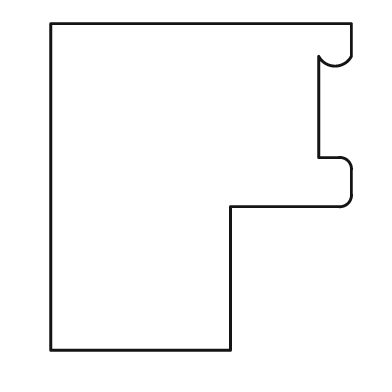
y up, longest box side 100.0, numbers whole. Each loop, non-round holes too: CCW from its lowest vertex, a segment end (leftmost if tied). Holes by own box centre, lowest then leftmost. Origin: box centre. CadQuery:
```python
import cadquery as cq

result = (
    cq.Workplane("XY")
    .moveTo(-46.0, -50.0)
    .lineTo(9.0, -50.0)
    .lineTo(9.0, -6.0)
    .lineTo(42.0, -6.0)
    .threePointArc((45.0, -5.0), (46.0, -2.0))
    .lineTo(46.0, 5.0)
    .threePointArc((45.0, 8.0), (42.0, 9.0))
    .lineTo(36.0, 9.0)
    .lineTo(36.0, 40.0)
    .threePointArc((41.0, 37.0), (46.0, 40.0))
    .lineTo(46.0, 50.0)
    .lineTo(-46.0, 50.0)
    .close()
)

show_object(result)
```